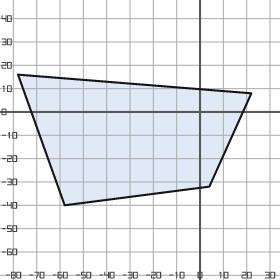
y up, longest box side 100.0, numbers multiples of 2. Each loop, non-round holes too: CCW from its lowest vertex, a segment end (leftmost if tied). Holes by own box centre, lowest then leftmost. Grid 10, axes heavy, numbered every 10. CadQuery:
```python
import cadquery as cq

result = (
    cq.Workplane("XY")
    .moveTo(-58.0, -40.0)
    .lineTo(4.0, -32.0)
    .lineTo(22.0, 8.0)
    .lineTo(-78.0, 16.0)
    .close()
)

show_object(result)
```